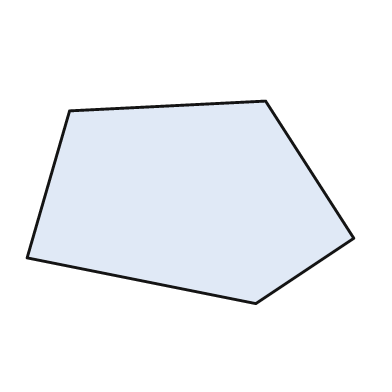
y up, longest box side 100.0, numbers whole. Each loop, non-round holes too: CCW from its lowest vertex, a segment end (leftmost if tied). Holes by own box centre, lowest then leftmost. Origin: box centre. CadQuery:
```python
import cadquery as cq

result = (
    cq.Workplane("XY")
    .moveTo(20.0, -31.0)
    .lineTo(50.0, -11.0)
    .lineTo(23.0, 31.0)
    .lineTo(-37.0, 28.0)
    .lineTo(-50.0, -17.0)
    .close()
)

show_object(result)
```